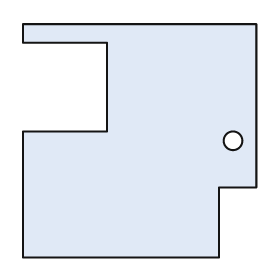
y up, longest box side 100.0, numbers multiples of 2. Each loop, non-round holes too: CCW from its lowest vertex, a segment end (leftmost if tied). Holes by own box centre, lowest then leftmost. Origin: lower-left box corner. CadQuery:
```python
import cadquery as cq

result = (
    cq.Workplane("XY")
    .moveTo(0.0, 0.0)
    .lineTo(84.0, 0.0)
    .lineTo(84.0, 30.0)
    .lineTo(100.0, 30.0)
    .lineTo(100.0, 100.0)
    .lineTo(0.0, 100.0)
    .lineTo(0.0, 92.0)
    .lineTo(36.0, 92.0)
    .lineTo(36.0, 54.0)
    .lineTo(0.0, 54.0)
    .close()
    .moveTo(90.0, 50.0)
    .circle(4.0)
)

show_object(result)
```